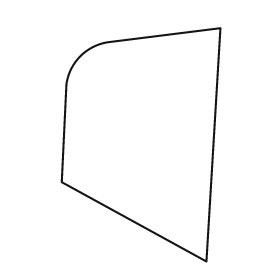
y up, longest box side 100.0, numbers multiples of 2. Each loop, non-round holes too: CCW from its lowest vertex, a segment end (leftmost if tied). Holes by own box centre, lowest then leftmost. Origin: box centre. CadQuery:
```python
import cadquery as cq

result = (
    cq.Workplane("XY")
    .moveTo(28.0, -50.0)
    .lineTo(34.0, 50.0)
    .lineTo(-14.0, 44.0)
    .threePointArc((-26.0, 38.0), (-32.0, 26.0))
    .lineTo(-34.0, -16.0)
    .close()
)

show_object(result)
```